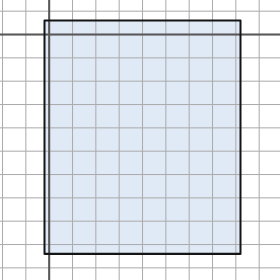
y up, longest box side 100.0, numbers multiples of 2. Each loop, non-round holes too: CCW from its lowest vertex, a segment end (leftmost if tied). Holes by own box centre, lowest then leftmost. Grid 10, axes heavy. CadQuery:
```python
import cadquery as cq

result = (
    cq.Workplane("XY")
    .moveTo(-2.0, -94.0)
    .lineTo(82.0, -94.0)
    .lineTo(82.0, 6.0)
    .lineTo(-2.0, 6.0)
    .close()
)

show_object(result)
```